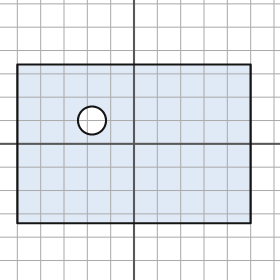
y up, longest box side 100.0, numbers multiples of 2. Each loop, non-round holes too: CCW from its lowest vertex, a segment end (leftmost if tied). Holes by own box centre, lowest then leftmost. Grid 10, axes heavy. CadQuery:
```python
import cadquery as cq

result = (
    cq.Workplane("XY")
    .moveTo(-50.0, -34.0)
    .lineTo(50.0, -34.0)
    .lineTo(50.0, 34.0)
    .lineTo(-50.0, 34.0)
    .close()
    .moveTo(-18.0, 10.0)
    .circle(6.0)
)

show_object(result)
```